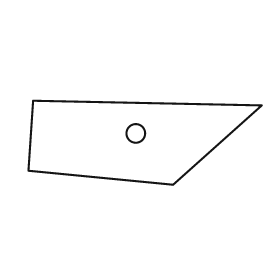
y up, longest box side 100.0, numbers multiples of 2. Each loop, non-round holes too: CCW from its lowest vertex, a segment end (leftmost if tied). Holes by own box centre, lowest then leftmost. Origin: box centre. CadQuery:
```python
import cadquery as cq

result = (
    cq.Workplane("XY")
    .moveTo(12.0, -18.0)
    .lineTo(50.0, 16.0)
    .lineTo(-48.0, 18.0)
    .lineTo(-50.0, -12.0)
    .close()
    .moveTo(-4.0, 4.0)
    .circle(4.0)
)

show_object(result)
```